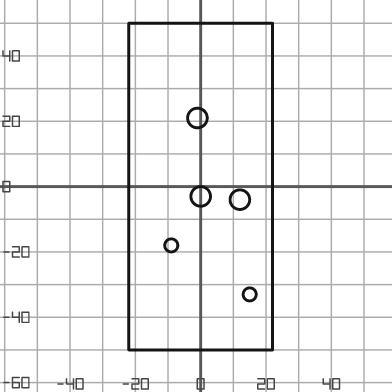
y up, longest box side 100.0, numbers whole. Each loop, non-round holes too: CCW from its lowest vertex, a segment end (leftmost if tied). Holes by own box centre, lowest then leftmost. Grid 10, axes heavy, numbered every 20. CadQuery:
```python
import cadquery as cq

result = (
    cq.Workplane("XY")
    .moveTo(-22.0, -50.0)
    .lineTo(22.0, -50.0)
    .lineTo(22.0, 50.0)
    .lineTo(-22.0, 50.0)
    .close()
    .moveTo(15.0, -33.0)
    .circle(2.0)
    .moveTo(-9.0, -18.0)
    .circle(2.0)
    .moveTo(12.0, -4.0)
    .circle(3.0)
    .moveTo(0.0, -3.0)
    .circle(3.0)
    .moveTo(-1.0, 21.0)
    .circle(3.0)
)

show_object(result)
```